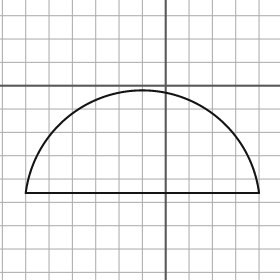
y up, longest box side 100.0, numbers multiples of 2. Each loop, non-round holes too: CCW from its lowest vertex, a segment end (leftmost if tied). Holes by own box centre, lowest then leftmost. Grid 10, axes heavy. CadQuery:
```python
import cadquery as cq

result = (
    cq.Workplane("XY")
    .moveTo(-60.0, -46.0)
    .lineTo(40.0, -46.0)
    .threePointArc((-10.0, -2.0), (-60.0, -46.0))
    .close()
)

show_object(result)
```